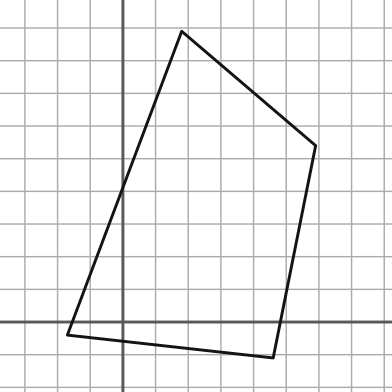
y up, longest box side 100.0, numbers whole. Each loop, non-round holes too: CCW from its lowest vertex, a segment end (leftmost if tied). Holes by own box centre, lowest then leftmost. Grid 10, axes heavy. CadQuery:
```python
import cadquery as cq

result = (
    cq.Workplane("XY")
    .moveTo(46.0, -11.0)
    .lineTo(59.0, 54.0)
    .lineTo(18.0, 89.0)
    .lineTo(-17.0, -4.0)
    .close()
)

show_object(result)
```